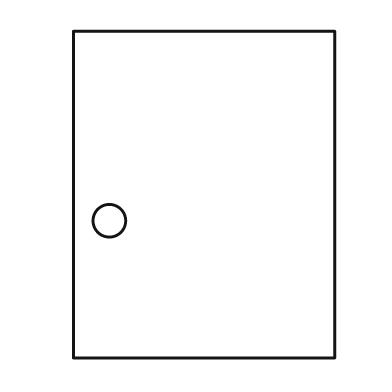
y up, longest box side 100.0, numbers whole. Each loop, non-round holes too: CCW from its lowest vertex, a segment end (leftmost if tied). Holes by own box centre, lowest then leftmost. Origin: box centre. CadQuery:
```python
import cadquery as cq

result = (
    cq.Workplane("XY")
    .moveTo(-40.0, -50.0)
    .lineTo(40.0, -50.0)
    .lineTo(40.0, 50.0)
    .lineTo(-40.0, 50.0)
    .close()
    .moveTo(-29.0, -8.0)
    .circle(5.0)
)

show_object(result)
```